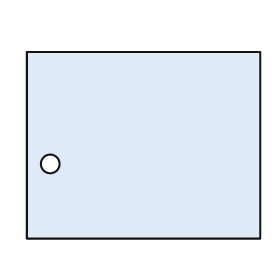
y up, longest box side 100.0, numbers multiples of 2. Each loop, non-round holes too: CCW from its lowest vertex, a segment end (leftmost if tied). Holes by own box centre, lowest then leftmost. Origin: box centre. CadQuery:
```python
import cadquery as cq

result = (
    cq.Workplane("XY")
    .moveTo(-50.0, -40.0)
    .lineTo(50.0, -40.0)
    .lineTo(50.0, 40.0)
    .lineTo(-50.0, 40.0)
    .close()
    .moveTo(-40.0, -8.0)
    .circle(4.0)
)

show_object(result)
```